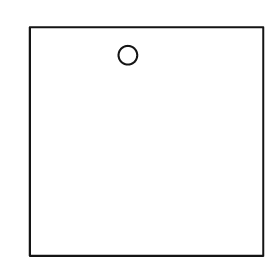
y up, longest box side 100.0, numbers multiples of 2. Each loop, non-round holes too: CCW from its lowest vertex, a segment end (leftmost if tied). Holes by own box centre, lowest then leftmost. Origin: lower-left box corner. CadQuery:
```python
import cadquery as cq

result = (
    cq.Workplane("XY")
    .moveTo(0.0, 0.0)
    .lineTo(100.0, 0.0)
    .lineTo(100.0, 98.0)
    .lineTo(0.0, 98.0)
    .close()
    .moveTo(42.0, 86.0)
    .circle(4.0)
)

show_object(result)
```